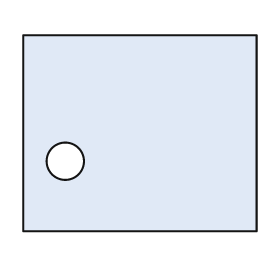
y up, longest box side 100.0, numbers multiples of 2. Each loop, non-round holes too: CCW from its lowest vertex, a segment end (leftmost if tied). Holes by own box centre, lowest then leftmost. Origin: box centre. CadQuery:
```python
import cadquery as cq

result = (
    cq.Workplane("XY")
    .moveTo(-50.0, -42.0)
    .lineTo(50.0, -42.0)
    .lineTo(50.0, 42.0)
    .lineTo(-50.0, 42.0)
    .close()
    .moveTo(-32.0, -12.0)
    .circle(8.0)
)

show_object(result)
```